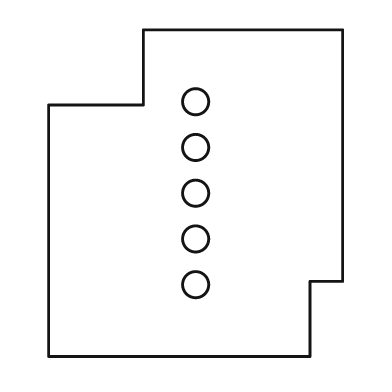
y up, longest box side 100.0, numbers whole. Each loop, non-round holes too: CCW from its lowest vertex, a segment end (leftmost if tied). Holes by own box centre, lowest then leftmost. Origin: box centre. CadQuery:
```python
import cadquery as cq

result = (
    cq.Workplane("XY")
    .moveTo(-45.0, -50.0)
    .lineTo(35.0, -50.0)
    .lineTo(35.0, -27.0)
    .lineTo(45.0, -27.0)
    .lineTo(45.0, 50.0)
    .lineTo(-16.0, 50.0)
    .lineTo(-16.0, 27.0)
    .lineTo(-45.0, 27.0)
    .close()
    .moveTo(0.0, -28.0)
    .circle(4.0)
    .moveTo(0.0, -14.0)
    .circle(4.0)
    .moveTo(0.0, 0.0)
    .circle(4.0)
    .moveTo(0.0, 14.0)
    .circle(4.0)
    .moveTo(0.0, 28.0)
    .circle(4.0)
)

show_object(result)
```